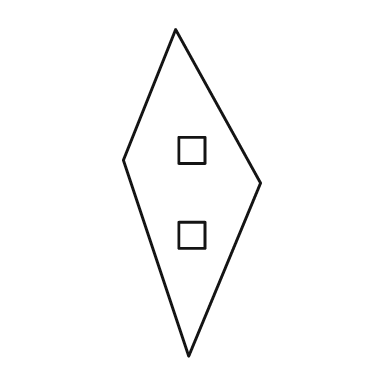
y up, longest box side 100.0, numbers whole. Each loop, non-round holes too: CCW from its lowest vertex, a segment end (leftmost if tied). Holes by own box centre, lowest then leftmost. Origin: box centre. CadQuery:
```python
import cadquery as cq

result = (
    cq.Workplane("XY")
    .moveTo(-1.0, -50.0)
    .lineTo(21.0, 3.0)
    .lineTo(-5.0, 50.0)
    .lineTo(-21.0, 10.0)
    .close()
    .moveTo(-4.0, -17.0)
    .lineTo(4.0, -17.0)
    .lineTo(4.0, -9.0)
    .lineTo(-4.0, -9.0)
    .close()
    .moveTo(-4.0, 9.0)
    .lineTo(4.0, 9.0)
    .lineTo(4.0, 17.0)
    .lineTo(-4.0, 17.0)
    .close()
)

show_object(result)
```